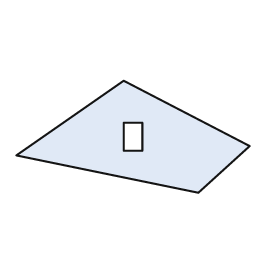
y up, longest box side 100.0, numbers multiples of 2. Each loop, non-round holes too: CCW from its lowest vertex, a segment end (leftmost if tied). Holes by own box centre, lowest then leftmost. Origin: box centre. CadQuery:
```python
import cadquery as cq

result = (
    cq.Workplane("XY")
    .moveTo(28.0, -24.0)
    .lineTo(50.0, -4.0)
    .lineTo(-4.0, 24.0)
    .lineTo(-50.0, -8.0)
    .close()
    .moveTo(-4.0, -6.0)
    .lineTo(4.0, -6.0)
    .lineTo(4.0, 6.0)
    .lineTo(-4.0, 6.0)
    .close()
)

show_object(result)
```